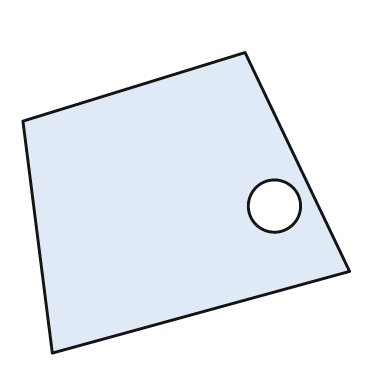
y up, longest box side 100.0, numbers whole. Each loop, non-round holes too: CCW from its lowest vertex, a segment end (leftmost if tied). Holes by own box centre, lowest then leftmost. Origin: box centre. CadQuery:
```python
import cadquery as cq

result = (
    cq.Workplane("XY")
    .moveTo(-41.0, -46.0)
    .lineTo(50.0, -21.0)
    .lineTo(18.0, 46.0)
    .lineTo(-50.0, 25.0)
    .close()
    .moveTo(27.0, -1.0)
    .circle(8.0)
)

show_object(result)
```